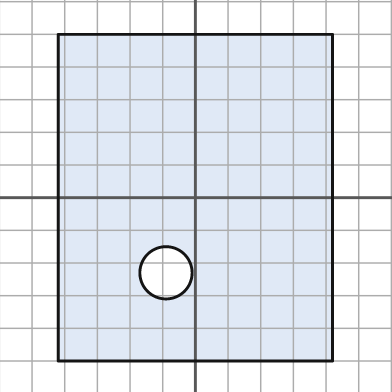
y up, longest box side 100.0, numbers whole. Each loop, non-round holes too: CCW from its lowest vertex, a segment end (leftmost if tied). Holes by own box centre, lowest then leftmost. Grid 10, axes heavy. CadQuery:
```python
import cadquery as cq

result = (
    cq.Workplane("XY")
    .moveTo(-42.0, -50.0)
    .lineTo(42.0, -50.0)
    .lineTo(42.0, 50.0)
    .lineTo(-42.0, 50.0)
    .close()
    .moveTo(-9.0, -23.0)
    .circle(8.0)
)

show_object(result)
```